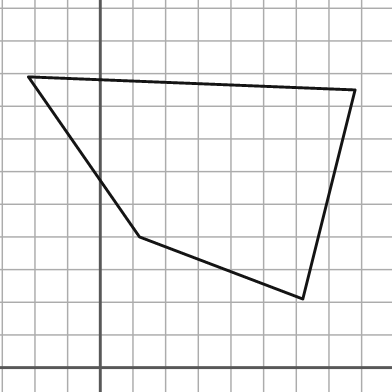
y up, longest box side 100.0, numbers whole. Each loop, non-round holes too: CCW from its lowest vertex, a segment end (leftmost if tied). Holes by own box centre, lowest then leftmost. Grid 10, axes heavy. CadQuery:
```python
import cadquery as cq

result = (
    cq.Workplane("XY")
    .moveTo(62.0, 21.0)
    .lineTo(78.0, 85.0)
    .lineTo(-22.0, 89.0)
    .lineTo(12.0, 40.0)
    .close()
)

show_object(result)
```